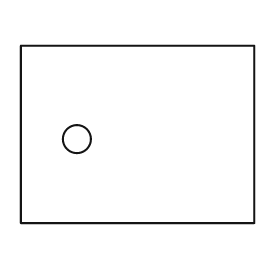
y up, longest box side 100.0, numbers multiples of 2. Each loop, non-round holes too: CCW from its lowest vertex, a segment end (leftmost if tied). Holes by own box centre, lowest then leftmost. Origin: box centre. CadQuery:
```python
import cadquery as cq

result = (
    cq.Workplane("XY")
    .moveTo(-50.0, -38.0)
    .lineTo(50.0, -38.0)
    .lineTo(50.0, 38.0)
    .lineTo(-50.0, 38.0)
    .close()
    .moveTo(-26.0, -2.0)
    .circle(6.0)
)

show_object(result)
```